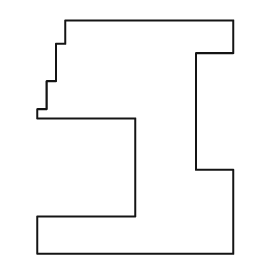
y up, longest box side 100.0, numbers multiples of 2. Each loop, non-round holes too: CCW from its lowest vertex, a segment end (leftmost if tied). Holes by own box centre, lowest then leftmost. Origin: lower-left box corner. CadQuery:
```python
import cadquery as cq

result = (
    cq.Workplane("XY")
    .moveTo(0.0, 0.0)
    .lineTo(84.0, 0.0)
    .lineTo(84.0, 36.0)
    .lineTo(68.0, 36.0)
    .lineTo(68.0, 86.0)
    .lineTo(84.0, 86.0)
    .lineTo(84.0, 100.0)
    .lineTo(12.0, 100.0)
    .lineTo(12.0, 90.0)
    .lineTo(8.0, 90.0)
    .lineTo(8.0, 74.0)
    .lineTo(4.0, 74.0)
    .lineTo(4.0, 62.0)
    .lineTo(0.0, 62.0)
    .lineTo(0.0, 58.0)
    .lineTo(42.0, 58.0)
    .lineTo(42.0, 16.0)
    .lineTo(0.0, 16.0)
    .close()
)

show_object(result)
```